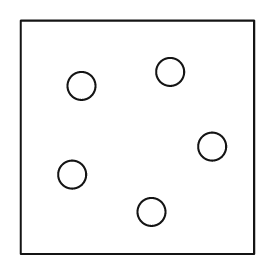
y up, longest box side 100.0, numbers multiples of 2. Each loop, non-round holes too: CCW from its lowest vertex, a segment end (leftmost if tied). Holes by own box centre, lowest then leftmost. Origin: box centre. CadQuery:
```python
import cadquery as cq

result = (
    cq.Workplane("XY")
    .moveTo(-50.0, -50.0)
    .lineTo(50.0, -50.0)
    .lineTo(50.0, 50.0)
    .lineTo(-50.0, 50.0)
    .close()
    .moveTo(6.0, -32.0)
    .circle(6.0)
    .moveTo(-28.0, -16.0)
    .circle(6.0)
    .moveTo(32.0, -4.0)
    .circle(6.0)
    .moveTo(-24.0, 22.0)
    .circle(6.0)
    .moveTo(14.0, 28.0)
    .circle(6.0)
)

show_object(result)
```